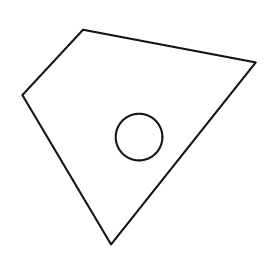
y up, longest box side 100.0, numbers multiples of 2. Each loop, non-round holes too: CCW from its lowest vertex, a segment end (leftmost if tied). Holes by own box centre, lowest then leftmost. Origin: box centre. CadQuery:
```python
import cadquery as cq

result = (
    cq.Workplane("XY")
    .moveTo(-12.0, -46.0)
    .lineTo(50.0, 32.0)
    .lineTo(-24.0, 46.0)
    .lineTo(-50.0, 18.0)
    .close()
    .moveTo(0.0, 0.0)
    .circle(10.0)
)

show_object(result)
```